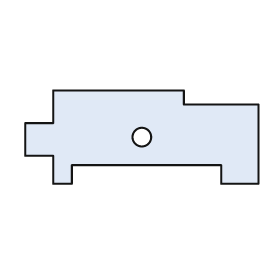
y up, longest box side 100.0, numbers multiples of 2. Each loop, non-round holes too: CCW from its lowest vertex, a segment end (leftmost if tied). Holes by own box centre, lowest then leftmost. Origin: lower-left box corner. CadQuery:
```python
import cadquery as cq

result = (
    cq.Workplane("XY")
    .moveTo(12.0, 0.0)
    .lineTo(20.0, 0.0)
    .lineTo(20.0, 8.0)
    .lineTo(84.0, 8.0)
    .lineTo(84.0, 0.0)
    .lineTo(100.0, 0.0)
    .lineTo(100.0, 34.0)
    .lineTo(68.0, 34.0)
    .lineTo(68.0, 40.0)
    .lineTo(12.0, 40.0)
    .lineTo(12.0, 26.0)
    .lineTo(0.0, 26.0)
    .lineTo(0.0, 12.0)
    .lineTo(12.0, 12.0)
    .close()
    .moveTo(50.0, 20.0)
    .circle(4.0)
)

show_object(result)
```